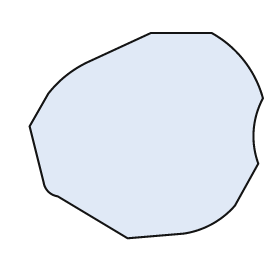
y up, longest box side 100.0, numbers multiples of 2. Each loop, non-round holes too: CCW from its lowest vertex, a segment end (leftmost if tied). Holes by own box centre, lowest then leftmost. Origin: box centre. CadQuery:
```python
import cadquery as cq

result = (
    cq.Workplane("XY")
    .moveTo(-8.0, -44.0)
    .lineTo(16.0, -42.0)
    .threePointArc((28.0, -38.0), (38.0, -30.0))
    .lineTo(48.0, -12.0)
    .threePointArc((46.0, 2.0), (50.0, 16.0))
    .threePointArc((42.0, 32.0), (28.0, 44.0))
    .lineTo(2.0, 44.0)
    .lineTo(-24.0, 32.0)
    .threePointArc((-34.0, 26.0), (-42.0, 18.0))
    .lineTo(-50.0, 4.0)
    .lineTo(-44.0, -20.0)
    .threePointArc((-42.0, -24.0), (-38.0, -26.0))
    .close()
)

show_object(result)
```